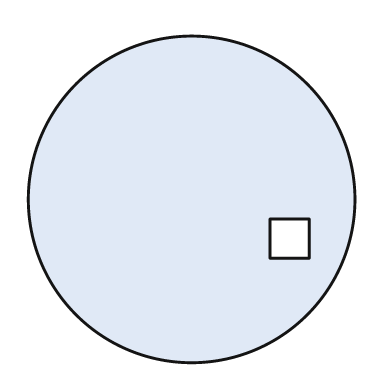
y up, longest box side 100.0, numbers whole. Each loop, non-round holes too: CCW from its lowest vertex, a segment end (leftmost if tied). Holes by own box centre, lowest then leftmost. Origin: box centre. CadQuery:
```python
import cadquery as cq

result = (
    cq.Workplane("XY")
    .moveTo(0.0, 0.0)
    .circle(50.0)
    .moveTo(24.0, -18.0)
    .lineTo(36.0, -18.0)
    .lineTo(36.0, -6.0)
    .lineTo(24.0, -6.0)
    .close()
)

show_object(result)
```